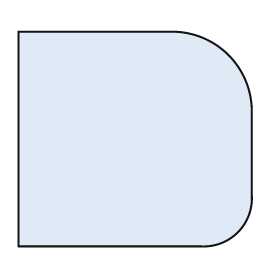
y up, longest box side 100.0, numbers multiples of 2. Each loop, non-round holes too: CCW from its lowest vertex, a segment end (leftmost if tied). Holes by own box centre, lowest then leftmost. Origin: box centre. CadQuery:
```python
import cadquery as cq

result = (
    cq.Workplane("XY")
    .moveTo(-50.0, -46.0)
    .lineTo(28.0, -46.0)
    .threePointArc((44.0, -40.0), (50.0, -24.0))
    .lineTo(50.0, 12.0)
    .threePointArc((40.0, 36.0), (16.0, 46.0))
    .lineTo(-50.0, 46.0)
    .close()
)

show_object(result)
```